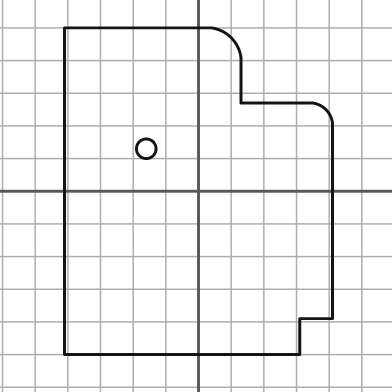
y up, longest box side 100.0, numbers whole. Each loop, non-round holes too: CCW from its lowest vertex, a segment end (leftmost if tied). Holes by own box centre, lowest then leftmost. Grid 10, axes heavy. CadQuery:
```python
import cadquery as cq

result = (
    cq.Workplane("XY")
    .moveTo(-41.0, -50.0)
    .lineTo(31.0, -50.0)
    .lineTo(31.0, -39.0)
    .lineTo(41.0, -39.0)
    .lineTo(41.0, 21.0)
    .threePointArc((39.0, 25.0), (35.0, 27.0))
    .lineTo(13.0, 27.0)
    .lineTo(13.0, 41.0)
    .threePointArc((10.0, 47.0), (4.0, 50.0))
    .lineTo(-41.0, 50.0)
    .close()
    .moveTo(-16.0, 13.0)
    .circle(3.0)
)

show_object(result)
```